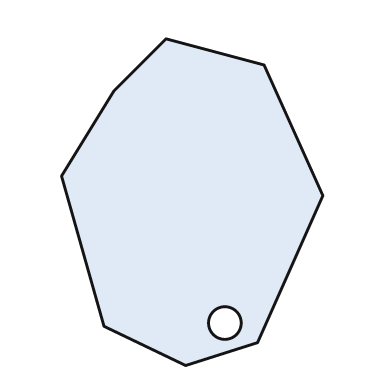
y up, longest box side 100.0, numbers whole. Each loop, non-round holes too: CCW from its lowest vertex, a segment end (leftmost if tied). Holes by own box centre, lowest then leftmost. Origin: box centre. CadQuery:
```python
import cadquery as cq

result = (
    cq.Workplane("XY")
    .moveTo(-2.0, -50.0)
    .lineTo(20.0, -43.0)
    .lineTo(40.0, 2.0)
    .lineTo(22.0, 42.0)
    .lineTo(-8.0, 50.0)
    .lineTo(-24.0, 34.0)
    .lineTo(-40.0, 8.0)
    .lineTo(-27.0, -38.0)
    .close()
    .moveTo(10.0, -37.0)
    .circle(5.0)
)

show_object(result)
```